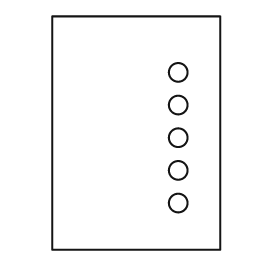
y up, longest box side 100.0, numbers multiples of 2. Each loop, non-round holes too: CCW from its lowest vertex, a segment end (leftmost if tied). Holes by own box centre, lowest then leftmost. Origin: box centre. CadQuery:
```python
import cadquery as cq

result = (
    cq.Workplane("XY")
    .moveTo(-36.0, -50.0)
    .lineTo(36.0, -50.0)
    .lineTo(36.0, 50.0)
    .lineTo(-36.0, 50.0)
    .close()
    .moveTo(18.0, -30.0)
    .circle(4.0)
    .moveTo(18.0, -16.0)
    .circle(4.0)
    .moveTo(18.0, -2.0)
    .circle(4.0)
    .moveTo(18.0, 12.0)
    .circle(4.0)
    .moveTo(18.0, 26.0)
    .circle(4.0)
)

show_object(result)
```